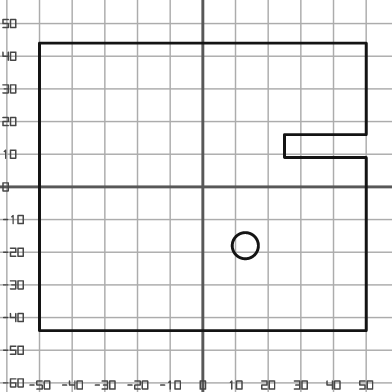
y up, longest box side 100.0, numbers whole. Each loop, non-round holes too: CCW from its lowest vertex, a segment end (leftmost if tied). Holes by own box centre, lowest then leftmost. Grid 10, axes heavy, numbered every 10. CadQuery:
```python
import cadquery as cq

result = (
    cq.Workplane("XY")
    .moveTo(-50.0, -44.0)
    .lineTo(50.0, -44.0)
    .lineTo(50.0, 9.0)
    .lineTo(25.0, 9.0)
    .lineTo(25.0, 16.0)
    .lineTo(50.0, 16.0)
    .lineTo(50.0, 44.0)
    .lineTo(-50.0, 44.0)
    .close()
    .moveTo(13.0, -18.0)
    .circle(4.0)
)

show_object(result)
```